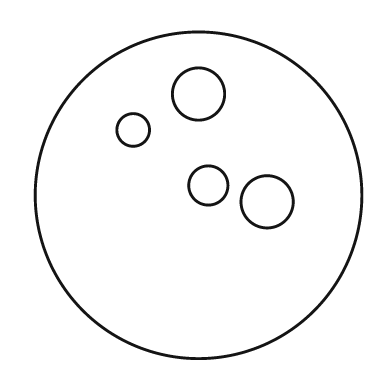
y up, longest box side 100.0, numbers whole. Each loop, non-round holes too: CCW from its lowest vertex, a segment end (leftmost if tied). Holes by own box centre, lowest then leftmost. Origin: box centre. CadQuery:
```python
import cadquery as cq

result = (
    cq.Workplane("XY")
    .moveTo(0.0, 0.0)
    .circle(50.0)
    .moveTo(21.0, -2.0)
    .circle(8.0)
    .moveTo(3.0, 3.0)
    .circle(6.0)
    .moveTo(-20.0, 20.0)
    .circle(5.0)
    .moveTo(0.0, 31.0)
    .circle(8.0)
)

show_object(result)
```